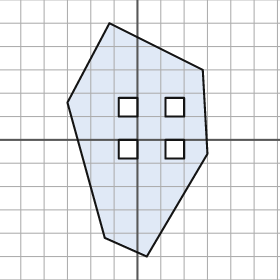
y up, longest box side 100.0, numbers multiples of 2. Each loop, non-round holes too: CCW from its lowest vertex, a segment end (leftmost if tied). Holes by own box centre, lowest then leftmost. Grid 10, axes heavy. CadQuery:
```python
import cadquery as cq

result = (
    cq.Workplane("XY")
    .moveTo(4.0, -50.0)
    .lineTo(30.0, -6.0)
    .lineTo(28.0, 30.0)
    .lineTo(-12.0, 50.0)
    .lineTo(-30.0, 16.0)
    .lineTo(-14.0, -42.0)
    .close()
    .moveTo(-8.0, -8.0)
    .lineTo(0.0, -8.0)
    .lineTo(0.0, 0.0)
    .lineTo(-8.0, 0.0)
    .close()
    .moveTo(12.0, -8.0)
    .lineTo(20.0, -8.0)
    .lineTo(20.0, 0.0)
    .lineTo(12.0, 0.0)
    .close()
    .moveTo(-8.0, 10.0)
    .lineTo(0.0, 10.0)
    .lineTo(0.0, 18.0)
    .lineTo(-8.0, 18.0)
    .close()
    .moveTo(12.0, 10.0)
    .lineTo(20.0, 10.0)
    .lineTo(20.0, 18.0)
    .lineTo(12.0, 18.0)
    .close()
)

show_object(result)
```